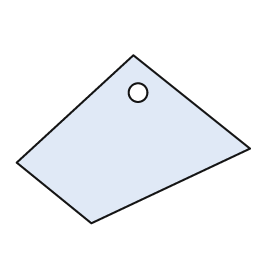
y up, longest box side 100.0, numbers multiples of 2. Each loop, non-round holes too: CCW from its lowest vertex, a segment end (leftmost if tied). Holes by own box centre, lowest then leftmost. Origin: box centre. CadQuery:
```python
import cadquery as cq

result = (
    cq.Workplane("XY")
    .moveTo(-18.0, -36.0)
    .lineTo(50.0, -4.0)
    .lineTo(0.0, 36.0)
    .lineTo(-50.0, -10.0)
    .close()
    .moveTo(2.0, 20.0)
    .circle(4.0)
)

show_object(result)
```